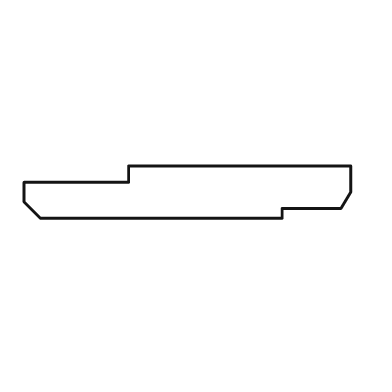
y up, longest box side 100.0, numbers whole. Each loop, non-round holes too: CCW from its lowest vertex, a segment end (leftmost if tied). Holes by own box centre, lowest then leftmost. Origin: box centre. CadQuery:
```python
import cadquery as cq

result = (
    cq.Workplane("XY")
    .moveTo(-45.0, -8.0)
    .lineTo(29.0, -8.0)
    .lineTo(29.0, -5.0)
    .lineTo(47.0, -5.0)
    .lineTo(50.0, 0.0)
    .lineTo(50.0, 8.0)
    .lineTo(-18.0, 8.0)
    .lineTo(-18.0, 3.0)
    .lineTo(-50.0, 3.0)
    .lineTo(-50.0, -3.0)
    .close()
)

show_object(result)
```